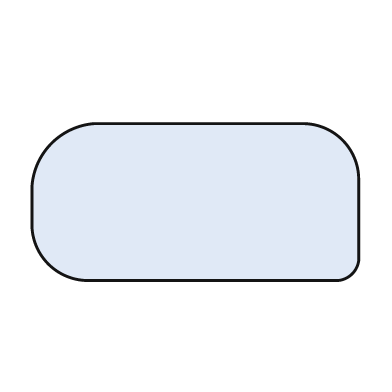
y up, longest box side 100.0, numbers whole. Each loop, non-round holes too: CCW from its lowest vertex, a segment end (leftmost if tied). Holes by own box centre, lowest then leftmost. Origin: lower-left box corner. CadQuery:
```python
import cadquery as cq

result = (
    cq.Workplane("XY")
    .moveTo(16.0, 0.0)
    .lineTo(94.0, 0.0)
    .threePointArc((98.0, 2.0), (100.0, 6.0))
    .lineTo(100.0, 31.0)
    .threePointArc((95.0, 43.0), (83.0, 48.0))
    .lineTo(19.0, 48.0)
    .threePointArc((6.0, 42.0), (0.0, 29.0))
    .lineTo(0.0, 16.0)
    .threePointArc((5.0, 5.0), (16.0, 0.0))
    .close()
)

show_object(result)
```